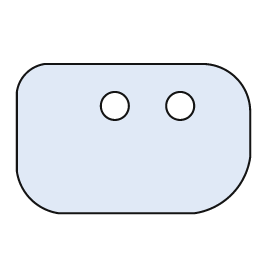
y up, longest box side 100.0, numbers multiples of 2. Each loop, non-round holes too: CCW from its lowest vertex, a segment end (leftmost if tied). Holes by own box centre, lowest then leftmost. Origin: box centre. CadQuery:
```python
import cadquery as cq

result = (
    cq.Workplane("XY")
    .moveTo(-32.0, -32.0)
    .lineTo(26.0, -32.0)
    .threePointArc((42.0, -24.0), (50.0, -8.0))
    .lineTo(50.0, 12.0)
    .threePointArc((44.0, 26.0), (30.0, 32.0))
    .lineTo(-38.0, 32.0)
    .threePointArc((-46.0, 28.0), (-50.0, 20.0))
    .lineTo(-50.0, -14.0)
    .threePointArc((-44.0, -26.0), (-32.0, -32.0))
    .close()
    .moveTo(-8.0, 14.0)
    .circle(6.0)
    .moveTo(20.0, 14.0)
    .circle(6.0)
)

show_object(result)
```